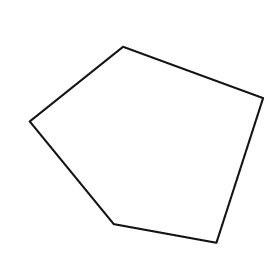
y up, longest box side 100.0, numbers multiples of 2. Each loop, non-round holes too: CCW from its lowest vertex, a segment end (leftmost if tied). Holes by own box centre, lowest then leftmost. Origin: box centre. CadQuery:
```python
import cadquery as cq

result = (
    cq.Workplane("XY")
    .moveTo(30.0, -42.0)
    .lineTo(50.0, 20.0)
    .lineTo(-10.0, 42.0)
    .lineTo(-50.0, 10.0)
    .lineTo(-14.0, -34.0)
    .close()
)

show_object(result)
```